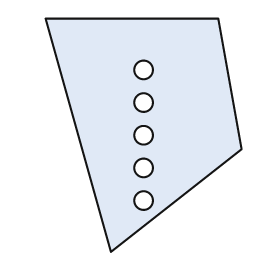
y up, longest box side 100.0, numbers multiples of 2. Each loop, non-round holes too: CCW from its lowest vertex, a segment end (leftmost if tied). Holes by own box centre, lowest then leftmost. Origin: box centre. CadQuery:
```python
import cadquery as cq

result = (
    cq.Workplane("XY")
    .moveTo(-14.0, -50.0)
    .lineTo(42.0, -6.0)
    .lineTo(32.0, 50.0)
    .lineTo(-42.0, 50.0)
    .close()
    .moveTo(0.0, -28.0)
    .circle(4.0)
    .moveTo(0.0, -14.0)
    .circle(4.0)
    .moveTo(0.0, 0.0)
    .circle(4.0)
    .moveTo(0.0, 14.0)
    .circle(4.0)
    .moveTo(0.0, 28.0)
    .circle(4.0)
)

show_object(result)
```